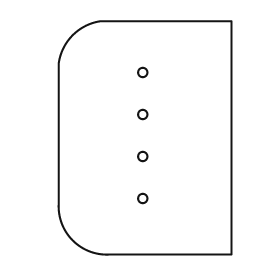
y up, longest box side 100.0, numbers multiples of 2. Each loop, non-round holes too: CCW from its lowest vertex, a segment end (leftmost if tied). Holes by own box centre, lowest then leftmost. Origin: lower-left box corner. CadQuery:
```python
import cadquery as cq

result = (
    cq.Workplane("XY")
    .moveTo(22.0, 0.0)
    .lineTo(74.0, 0.0)
    .lineTo(74.0, 100.0)
    .lineTo(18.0, 100.0)
    .threePointArc((6.0, 94.0), (0.0, 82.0))
    .lineTo(0.0, 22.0)
    .threePointArc((6.0, 6.0), (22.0, 0.0))
    .close()
    .moveTo(36.0, 24.0)
    .circle(2.0)
    .moveTo(36.0, 42.0)
    .circle(2.0)
    .moveTo(36.0, 60.0)
    .circle(2.0)
    .moveTo(36.0, 78.0)
    .circle(2.0)
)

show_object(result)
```